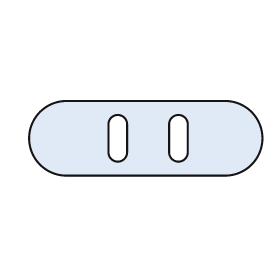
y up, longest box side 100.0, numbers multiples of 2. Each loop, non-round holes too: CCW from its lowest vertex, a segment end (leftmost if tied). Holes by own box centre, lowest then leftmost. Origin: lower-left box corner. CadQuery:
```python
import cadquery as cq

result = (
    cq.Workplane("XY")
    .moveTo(16.0, 0.0)
    .lineTo(84.0, 0.0)
    .threePointArc((100.0, 16.0), (84.0, 32.0))
    .lineTo(16.0, 32.0)
    .threePointArc((0.0, 16.0), (16.0, 0.0))
    .close()
    .moveTo(34.0, 10.0)
    .threePointArc((38.0, 6.0), (42.0, 10.0))
    .lineTo(42.0, 22.0)
    .threePointArc((38.0, 26.0), (34.0, 22.0))
    .close()
    .moveTo(60.0, 10.0)
    .threePointArc((64.0, 6.0), (68.0, 10.0))
    .lineTo(68.0, 22.0)
    .threePointArc((64.0, 26.0), (60.0, 22.0))
    .close()
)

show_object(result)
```